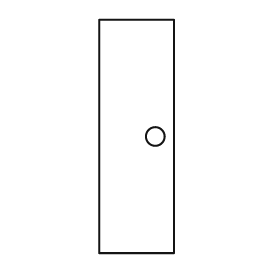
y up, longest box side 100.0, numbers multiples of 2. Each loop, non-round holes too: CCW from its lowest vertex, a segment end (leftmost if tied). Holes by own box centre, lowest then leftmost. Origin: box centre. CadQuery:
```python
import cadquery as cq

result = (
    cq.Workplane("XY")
    .moveTo(-16.0, -50.0)
    .lineTo(16.0, -50.0)
    .lineTo(16.0, 50.0)
    .lineTo(-16.0, 50.0)
    .close()
    .moveTo(8.0, 0.0)
    .circle(4.0)
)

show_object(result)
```